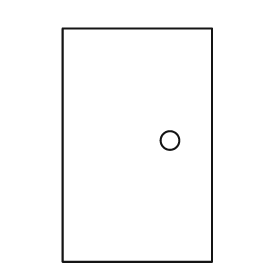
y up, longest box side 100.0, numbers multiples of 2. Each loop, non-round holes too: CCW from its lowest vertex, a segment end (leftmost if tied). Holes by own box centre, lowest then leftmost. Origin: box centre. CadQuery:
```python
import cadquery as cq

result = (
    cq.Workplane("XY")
    .moveTo(-32.0, -50.0)
    .lineTo(32.0, -50.0)
    .lineTo(32.0, 50.0)
    .lineTo(-32.0, 50.0)
    .close()
    .moveTo(14.0, 2.0)
    .circle(4.0)
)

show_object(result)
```